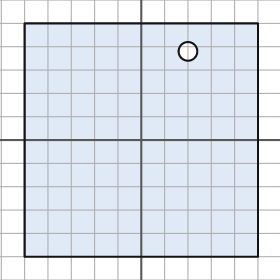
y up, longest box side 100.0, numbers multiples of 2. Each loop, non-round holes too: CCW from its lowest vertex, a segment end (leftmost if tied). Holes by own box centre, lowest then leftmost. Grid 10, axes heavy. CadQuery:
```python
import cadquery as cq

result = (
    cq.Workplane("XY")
    .moveTo(-50.0, -50.0)
    .lineTo(50.0, -50.0)
    .lineTo(50.0, 50.0)
    .lineTo(-50.0, 50.0)
    .close()
    .moveTo(20.0, 38.0)
    .circle(4.0)
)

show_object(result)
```